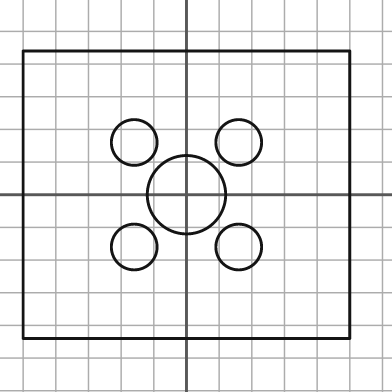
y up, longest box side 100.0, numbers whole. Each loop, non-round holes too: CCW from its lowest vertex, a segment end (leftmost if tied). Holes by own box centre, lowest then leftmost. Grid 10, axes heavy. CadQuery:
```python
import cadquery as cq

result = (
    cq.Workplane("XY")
    .moveTo(-50.0, -44.0)
    .lineTo(50.0, -44.0)
    .lineTo(50.0, 44.0)
    .lineTo(-50.0, 44.0)
    .close()
    .moveTo(-16.0, -16.0)
    .circle(7.0)
    .moveTo(16.0, -16.0)
    .circle(7.0)
    .moveTo(0.0, 0.0)
    .circle(12.0)
    .moveTo(-16.0, 16.0)
    .circle(7.0)
    .moveTo(16.0, 16.0)
    .circle(7.0)
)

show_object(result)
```